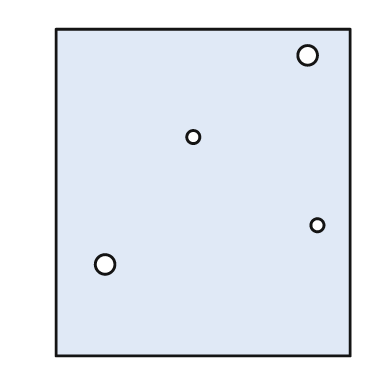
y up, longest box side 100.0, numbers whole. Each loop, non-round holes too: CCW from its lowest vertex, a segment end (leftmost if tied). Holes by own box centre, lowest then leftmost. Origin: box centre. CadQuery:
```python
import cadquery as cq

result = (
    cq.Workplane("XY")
    .moveTo(-45.0, -50.0)
    .lineTo(45.0, -50.0)
    .lineTo(45.0, 50.0)
    .lineTo(-45.0, 50.0)
    .close()
    .moveTo(-30.0, -22.0)
    .circle(3.0)
    .moveTo(35.0, -10.0)
    .circle(2.0)
    .moveTo(-3.0, 17.0)
    .circle(2.0)
    .moveTo(32.0, 42.0)
    .circle(3.0)
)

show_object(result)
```